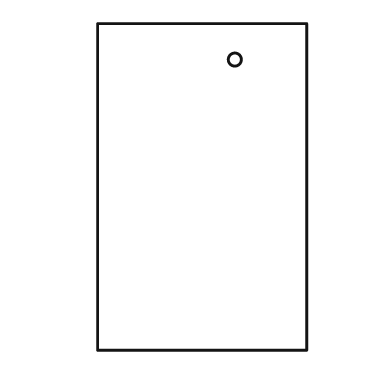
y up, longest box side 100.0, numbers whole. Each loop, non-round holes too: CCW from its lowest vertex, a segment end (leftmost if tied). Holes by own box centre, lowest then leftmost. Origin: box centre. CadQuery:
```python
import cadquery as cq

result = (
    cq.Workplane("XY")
    .moveTo(-32.0, -50.0)
    .lineTo(32.0, -50.0)
    .lineTo(32.0, 50.0)
    .lineTo(-32.0, 50.0)
    .close()
    .moveTo(10.0, 39.0)
    .circle(2.0)
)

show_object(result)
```